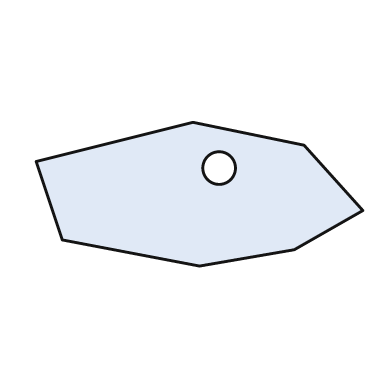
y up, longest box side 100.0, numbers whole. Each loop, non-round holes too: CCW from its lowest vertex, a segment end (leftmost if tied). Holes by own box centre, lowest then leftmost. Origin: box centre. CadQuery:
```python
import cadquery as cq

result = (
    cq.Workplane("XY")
    .moveTo(0.0, -22.0)
    .lineTo(29.0, -17.0)
    .lineTo(50.0, -5.0)
    .lineTo(32.0, 15.0)
    .lineTo(-2.0, 22.0)
    .lineTo(-50.0, 10.0)
    .lineTo(-42.0, -14.0)
    .close()
    .moveTo(6.0, 8.0)
    .circle(5.0)
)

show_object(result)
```